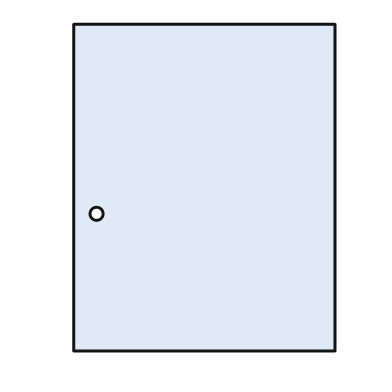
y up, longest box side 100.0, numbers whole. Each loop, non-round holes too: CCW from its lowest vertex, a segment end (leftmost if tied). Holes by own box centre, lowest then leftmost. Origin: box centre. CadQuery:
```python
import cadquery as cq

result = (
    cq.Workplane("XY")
    .moveTo(-40.0, -50.0)
    .lineTo(40.0, -50.0)
    .lineTo(40.0, 50.0)
    .lineTo(-40.0, 50.0)
    .close()
    .moveTo(-33.0, -8.0)
    .circle(2.0)
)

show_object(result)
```